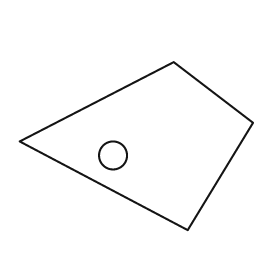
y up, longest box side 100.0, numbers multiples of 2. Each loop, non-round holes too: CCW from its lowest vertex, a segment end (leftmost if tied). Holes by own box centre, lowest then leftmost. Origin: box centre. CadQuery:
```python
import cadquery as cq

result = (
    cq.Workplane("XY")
    .moveTo(22.0, -36.0)
    .lineTo(50.0, 10.0)
    .lineTo(16.0, 36.0)
    .lineTo(-50.0, 2.0)
    .close()
    .moveTo(-10.0, -4.0)
    .circle(6.0)
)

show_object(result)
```